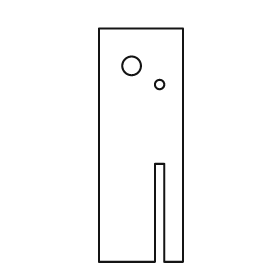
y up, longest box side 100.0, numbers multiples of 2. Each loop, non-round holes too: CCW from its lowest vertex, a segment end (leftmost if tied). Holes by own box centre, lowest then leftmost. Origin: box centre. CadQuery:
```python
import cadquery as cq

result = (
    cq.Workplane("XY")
    .moveTo(-18.0, -50.0)
    .lineTo(6.0, -50.0)
    .lineTo(6.0, -8.0)
    .lineTo(10.0, -8.0)
    .lineTo(10.0, -50.0)
    .lineTo(18.0, -50.0)
    .lineTo(18.0, 50.0)
    .lineTo(-18.0, 50.0)
    .close()
    .moveTo(8.0, 26.0)
    .circle(2.0)
    .moveTo(-4.0, 34.0)
    .circle(4.0)
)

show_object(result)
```